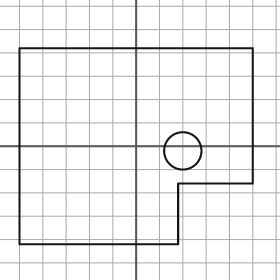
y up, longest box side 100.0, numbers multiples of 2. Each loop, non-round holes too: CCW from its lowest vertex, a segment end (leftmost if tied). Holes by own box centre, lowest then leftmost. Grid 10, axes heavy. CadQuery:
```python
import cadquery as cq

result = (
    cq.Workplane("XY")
    .moveTo(-50.0, -42.0)
    .lineTo(18.0, -42.0)
    .lineTo(18.0, -16.0)
    .lineTo(50.0, -16.0)
    .lineTo(50.0, 42.0)
    .lineTo(-50.0, 42.0)
    .close()
    .moveTo(20.0, -2.0)
    .circle(8.0)
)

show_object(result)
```